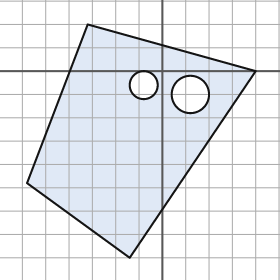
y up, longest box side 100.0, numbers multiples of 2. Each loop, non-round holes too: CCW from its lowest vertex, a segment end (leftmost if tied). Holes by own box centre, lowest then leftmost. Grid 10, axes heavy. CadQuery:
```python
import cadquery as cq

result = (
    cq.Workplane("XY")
    .moveTo(-14.0, -80.0)
    .lineTo(40.0, 0.0)
    .lineTo(-32.0, 20.0)
    .lineTo(-58.0, -48.0)
    .close()
    .moveTo(12.0, -10.0)
    .circle(8.0)
    .moveTo(-8.0, -6.0)
    .circle(6.0)
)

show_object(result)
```